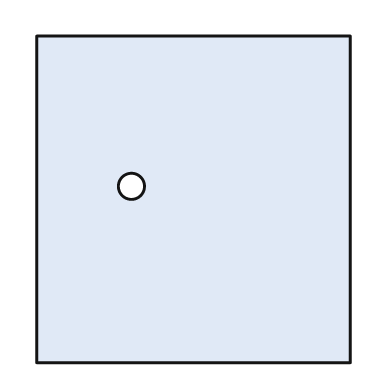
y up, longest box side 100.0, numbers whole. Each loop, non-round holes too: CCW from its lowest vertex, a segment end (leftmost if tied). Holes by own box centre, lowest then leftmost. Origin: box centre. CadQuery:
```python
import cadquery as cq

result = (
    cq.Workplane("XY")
    .moveTo(-48.0, -50.0)
    .lineTo(48.0, -50.0)
    .lineTo(48.0, 50.0)
    .lineTo(-48.0, 50.0)
    .close()
    .moveTo(-19.0, 4.0)
    .circle(4.0)
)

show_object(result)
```